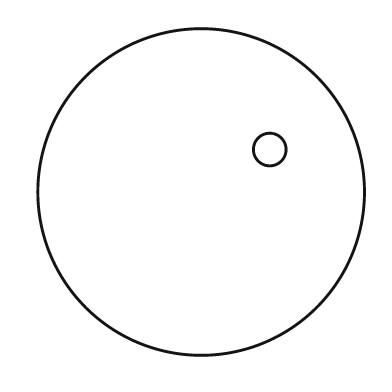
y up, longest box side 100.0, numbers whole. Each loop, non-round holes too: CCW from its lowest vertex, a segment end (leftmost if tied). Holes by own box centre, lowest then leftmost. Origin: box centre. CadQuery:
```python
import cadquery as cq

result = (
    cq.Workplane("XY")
    .moveTo(0.0, 0.0)
    .circle(50.0)
    .moveTo(21.0, 13.0)
    .circle(5.0)
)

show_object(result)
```